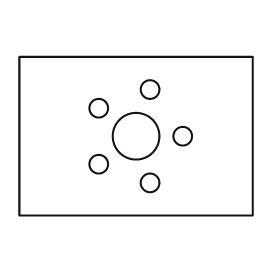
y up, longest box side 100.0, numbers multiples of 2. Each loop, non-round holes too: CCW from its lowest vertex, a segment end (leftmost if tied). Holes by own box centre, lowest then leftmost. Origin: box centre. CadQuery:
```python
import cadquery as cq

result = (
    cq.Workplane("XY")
    .moveTo(-50.0, -34.0)
    .lineTo(50.0, -34.0)
    .lineTo(50.0, 34.0)
    .lineTo(-50.0, 34.0)
    .close()
    .moveTo(6.0, -20.0)
    .circle(4.0)
    .moveTo(-16.0, -12.0)
    .circle(4.0)
    .moveTo(0.0, 0.0)
    .circle(10.0)
    .moveTo(20.0, 0.0)
    .circle(4.0)
    .moveTo(-16.0, 12.0)
    .circle(4.0)
    .moveTo(6.0, 20.0)
    .circle(4.0)
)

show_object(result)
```